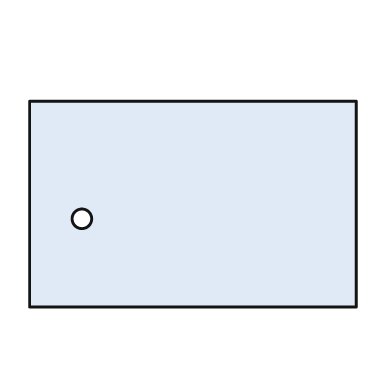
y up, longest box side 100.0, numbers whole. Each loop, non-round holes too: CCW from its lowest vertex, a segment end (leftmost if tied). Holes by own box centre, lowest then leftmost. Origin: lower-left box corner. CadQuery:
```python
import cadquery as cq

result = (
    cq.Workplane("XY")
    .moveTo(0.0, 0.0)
    .lineTo(100.0, 0.0)
    .lineTo(100.0, 63.0)
    .lineTo(0.0, 63.0)
    .close()
    .moveTo(16.0, 27.0)
    .circle(3.0)
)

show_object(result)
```